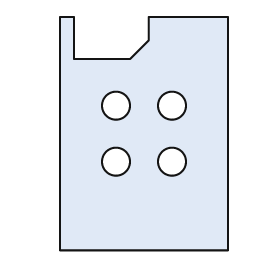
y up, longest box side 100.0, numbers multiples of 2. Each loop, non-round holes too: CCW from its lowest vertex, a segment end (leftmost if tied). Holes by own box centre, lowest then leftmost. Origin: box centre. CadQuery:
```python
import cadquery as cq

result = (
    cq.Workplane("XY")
    .moveTo(-36.0, -50.0)
    .lineTo(36.0, -50.0)
    .lineTo(36.0, 50.0)
    .lineTo(2.0, 50.0)
    .lineTo(2.0, 40.0)
    .lineTo(-6.0, 32.0)
    .lineTo(-30.0, 32.0)
    .lineTo(-30.0, 50.0)
    .lineTo(-36.0, 50.0)
    .close()
    .moveTo(-12.0, -12.0)
    .circle(6.0)
    .moveTo(12.0, -12.0)
    .circle(6.0)
    .moveTo(-12.0, 12.0)
    .circle(6.0)
    .moveTo(12.0, 12.0)
    .circle(6.0)
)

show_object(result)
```